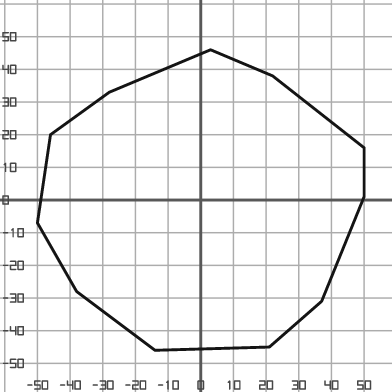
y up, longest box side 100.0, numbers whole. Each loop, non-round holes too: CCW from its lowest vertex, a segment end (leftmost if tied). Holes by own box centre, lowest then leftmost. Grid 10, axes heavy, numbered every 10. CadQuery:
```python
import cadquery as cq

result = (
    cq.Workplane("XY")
    .moveTo(-14.0, -46.0)
    .lineTo(21.0, -45.0)
    .lineTo(37.0, -31.0)
    .lineTo(50.0, 1.0)
    .lineTo(50.0, 16.0)
    .lineTo(22.0, 38.0)
    .lineTo(3.0, 46.0)
    .lineTo(-28.0, 33.0)
    .lineTo(-46.0, 20.0)
    .lineTo(-50.0, -7.0)
    .lineTo(-38.0, -28.0)
    .close()
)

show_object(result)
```